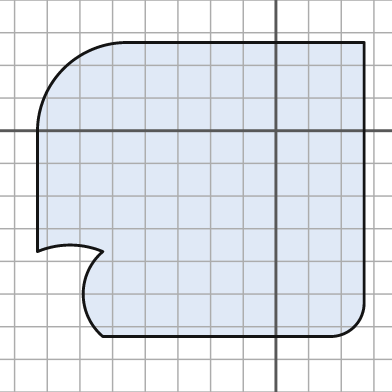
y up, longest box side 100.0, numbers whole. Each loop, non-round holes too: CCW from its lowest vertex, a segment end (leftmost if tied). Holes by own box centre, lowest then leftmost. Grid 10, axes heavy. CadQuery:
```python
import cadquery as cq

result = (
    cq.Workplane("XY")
    .moveTo(-53.0, -63.0)
    .lineTo(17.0, -63.0)
    .threePointArc((24.0, -60.0), (27.0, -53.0))
    .lineTo(27.0, 27.0)
    .lineTo(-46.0, 27.0)
    .threePointArc((-65.0, 19.0), (-73.0, 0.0))
    .lineTo(-73.0, -37.0)
    .threePointArc((-63.0, -35.0), (-53.0, -37.0))
    .threePointArc((-59.0, -50.0), (-53.0, -63.0))
    .close()
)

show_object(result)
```